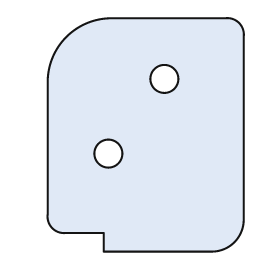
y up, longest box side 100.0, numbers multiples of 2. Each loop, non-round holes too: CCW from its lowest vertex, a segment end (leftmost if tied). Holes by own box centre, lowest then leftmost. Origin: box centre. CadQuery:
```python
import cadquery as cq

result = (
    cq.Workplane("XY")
    .moveTo(-18.0, -50.0)
    .lineTo(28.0, -50.0)
    .threePointArc((38.0, -46.0), (42.0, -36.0))
    .lineTo(42.0, 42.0)
    .threePointArc((40.0, 48.0), (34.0, 50.0))
    .lineTo(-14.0, 50.0)
    .threePointArc((-34.0, 42.0), (-42.0, 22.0))
    .lineTo(-42.0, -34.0)
    .threePointArc((-40.0, -40.0), (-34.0, -42.0))
    .lineTo(-18.0, -42.0)
    .close()
    .moveTo(-16.0, -8.0)
    .circle(6.0)
    .moveTo(8.0, 24.0)
    .circle(6.0)
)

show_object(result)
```